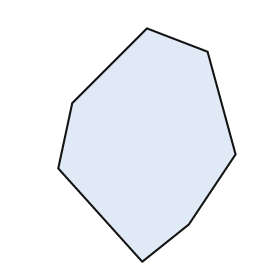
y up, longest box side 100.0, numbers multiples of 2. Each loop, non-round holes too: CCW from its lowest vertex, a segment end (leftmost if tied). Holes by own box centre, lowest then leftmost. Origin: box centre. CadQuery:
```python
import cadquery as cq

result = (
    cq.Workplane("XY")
    .moveTo(-2.0, -50.0)
    .lineTo(18.0, -34.0)
    .lineTo(38.0, -4.0)
    .lineTo(26.0, 40.0)
    .lineTo(0.0, 50.0)
    .lineTo(-32.0, 18.0)
    .lineTo(-38.0, -10.0)
    .close()
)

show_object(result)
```